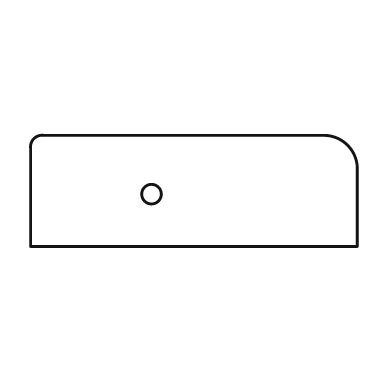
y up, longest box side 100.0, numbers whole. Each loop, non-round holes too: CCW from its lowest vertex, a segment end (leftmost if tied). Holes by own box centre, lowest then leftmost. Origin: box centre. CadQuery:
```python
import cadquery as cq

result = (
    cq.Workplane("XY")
    .moveTo(-50.0, -17.0)
    .lineTo(50.0, -17.0)
    .lineTo(50.0, 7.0)
    .threePointArc((47.0, 14.0), (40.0, 17.0))
    .lineTo(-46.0, 17.0)
    .threePointArc((-49.0, 16.0), (-50.0, 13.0))
    .close()
    .moveTo(-13.0, -1.0)
    .circle(3.0)
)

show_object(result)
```